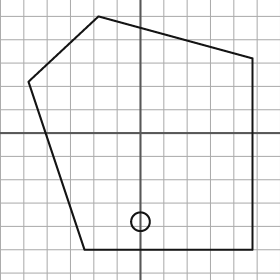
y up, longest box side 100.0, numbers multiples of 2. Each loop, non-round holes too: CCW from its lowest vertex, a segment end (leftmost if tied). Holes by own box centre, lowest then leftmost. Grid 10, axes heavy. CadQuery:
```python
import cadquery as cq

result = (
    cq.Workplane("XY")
    .moveTo(-24.0, -50.0)
    .lineTo(48.0, -50.0)
    .lineTo(48.0, 32.0)
    .lineTo(-18.0, 50.0)
    .lineTo(-48.0, 22.0)
    .close()
    .moveTo(0.0, -38.0)
    .circle(4.0)
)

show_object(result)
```